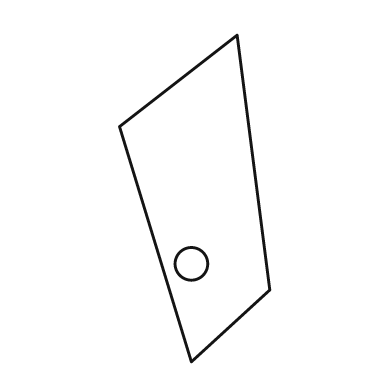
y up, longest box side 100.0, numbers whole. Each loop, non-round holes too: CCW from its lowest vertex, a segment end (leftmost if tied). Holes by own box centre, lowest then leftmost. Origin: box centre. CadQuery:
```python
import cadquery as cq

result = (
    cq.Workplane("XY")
    .moveTo(-1.0, -50.0)
    .lineTo(23.0, -28.0)
    .lineTo(13.0, 50.0)
    .lineTo(-23.0, 22.0)
    .close()
    .moveTo(-1.0, -20.0)
    .circle(5.0)
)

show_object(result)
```